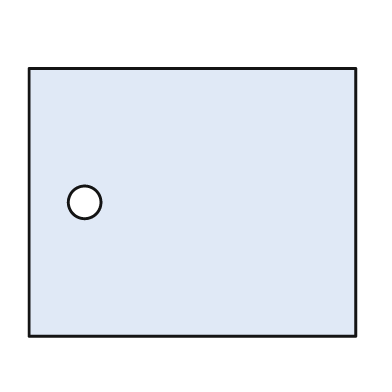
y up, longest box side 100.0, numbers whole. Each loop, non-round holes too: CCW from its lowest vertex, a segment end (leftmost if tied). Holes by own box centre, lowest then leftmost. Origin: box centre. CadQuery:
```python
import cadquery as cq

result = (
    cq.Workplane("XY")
    .moveTo(-50.0, -41.0)
    .lineTo(50.0, -41.0)
    .lineTo(50.0, 41.0)
    .lineTo(-50.0, 41.0)
    .close()
    .moveTo(-33.0, 0.0)
    .circle(5.0)
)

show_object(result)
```